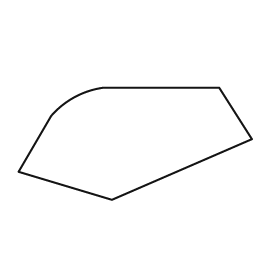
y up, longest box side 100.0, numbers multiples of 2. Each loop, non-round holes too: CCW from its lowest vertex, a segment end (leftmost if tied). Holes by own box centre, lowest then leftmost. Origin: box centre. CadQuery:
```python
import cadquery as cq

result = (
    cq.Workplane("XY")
    .moveTo(-10.0, -24.0)
    .lineTo(50.0, 2.0)
    .lineTo(36.0, 24.0)
    .lineTo(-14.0, 24.0)
    .threePointArc((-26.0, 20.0), (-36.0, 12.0))
    .lineTo(-50.0, -12.0)
    .close()
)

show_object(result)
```